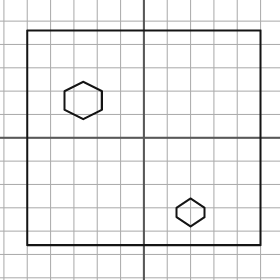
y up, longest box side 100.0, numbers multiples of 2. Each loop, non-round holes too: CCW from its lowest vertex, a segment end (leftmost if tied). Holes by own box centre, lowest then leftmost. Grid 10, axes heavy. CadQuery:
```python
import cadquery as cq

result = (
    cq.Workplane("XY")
    .moveTo(-50.0, -46.0)
    .lineTo(50.0, -46.0)
    .lineTo(50.0, 46.0)
    .lineTo(-50.0, 46.0)
    .close()
    .moveTo(20.0, -38.0)
    .lineTo(26.0, -34.0)
    .lineTo(26.0, -30.0)
    .lineTo(20.0, -26.0)
    .lineTo(14.0, -30.0)
    .lineTo(14.0, -34.0)
    .close()
    .moveTo(-26.0, 8.0)
    .lineTo(-18.0, 12.0)
    .lineTo(-18.0, 20.0)
    .lineTo(-26.0, 24.0)
    .lineTo(-34.0, 20.0)
    .lineTo(-34.0, 12.0)
    .close()
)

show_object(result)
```